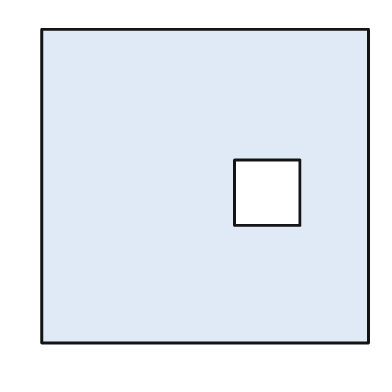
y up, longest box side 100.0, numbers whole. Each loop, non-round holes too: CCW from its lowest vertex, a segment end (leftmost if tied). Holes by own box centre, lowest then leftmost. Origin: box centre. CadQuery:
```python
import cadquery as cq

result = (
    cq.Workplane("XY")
    .moveTo(-50.0, -48.0)
    .lineTo(50.0, -48.0)
    .lineTo(50.0, 48.0)
    .lineTo(-50.0, 48.0)
    .close()
    .moveTo(9.0, -12.0)
    .lineTo(29.0, -12.0)
    .lineTo(29.0, 8.0)
    .lineTo(9.0, 8.0)
    .close()
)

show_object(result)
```